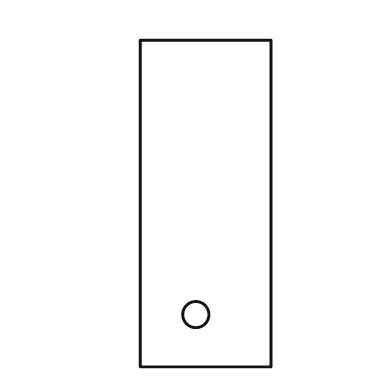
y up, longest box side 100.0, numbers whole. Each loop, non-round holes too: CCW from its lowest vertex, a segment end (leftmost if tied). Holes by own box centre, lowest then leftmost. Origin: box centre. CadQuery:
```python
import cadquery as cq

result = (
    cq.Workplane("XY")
    .moveTo(-20.0, -50.0)
    .lineTo(20.0, -50.0)
    .lineTo(20.0, 50.0)
    .lineTo(-20.0, 50.0)
    .close()
    .moveTo(-3.0, -34.0)
    .circle(4.0)
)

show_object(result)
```